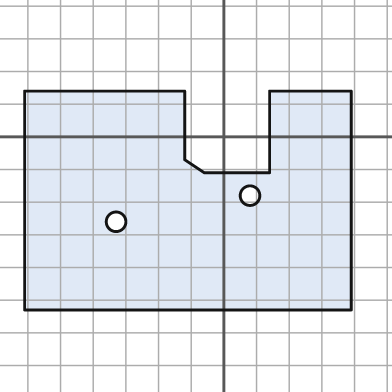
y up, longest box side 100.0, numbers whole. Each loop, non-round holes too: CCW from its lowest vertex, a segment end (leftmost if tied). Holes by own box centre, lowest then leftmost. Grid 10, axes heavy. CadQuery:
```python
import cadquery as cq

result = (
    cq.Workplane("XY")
    .moveTo(-61.0, -53.0)
    .lineTo(39.0, -53.0)
    .lineTo(39.0, 14.0)
    .lineTo(14.0, 14.0)
    .lineTo(14.0, -11.0)
    .lineTo(-6.0, -11.0)
    .lineTo(-12.0, -7.0)
    .lineTo(-12.0, 14.0)
    .lineTo(-61.0, 14.0)
    .close()
    .moveTo(-33.0, -26.0)
    .circle(3.0)
    .moveTo(8.0, -18.0)
    .circle(3.0)
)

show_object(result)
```